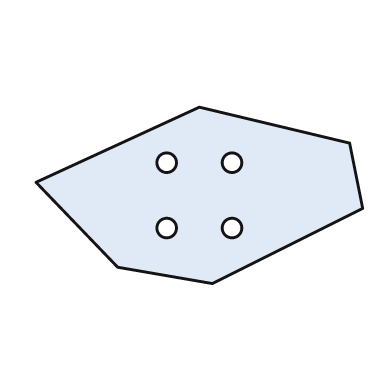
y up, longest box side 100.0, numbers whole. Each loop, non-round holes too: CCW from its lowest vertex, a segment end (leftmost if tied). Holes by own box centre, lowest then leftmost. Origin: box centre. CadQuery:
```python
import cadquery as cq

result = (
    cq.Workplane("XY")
    .moveTo(4.0, -27.0)
    .lineTo(50.0, -4.0)
    .lineTo(46.0, 16.0)
    .lineTo(0.0, 27.0)
    .lineTo(-50.0, 4.0)
    .lineTo(-25.0, -22.0)
    .close()
    .moveTo(-10.0, -10.0)
    .circle(3.0)
    .moveTo(10.0, -10.0)
    .circle(3.0)
    .moveTo(-10.0, 10.0)
    .circle(3.0)
    .moveTo(10.0, 10.0)
    .circle(3.0)
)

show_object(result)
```